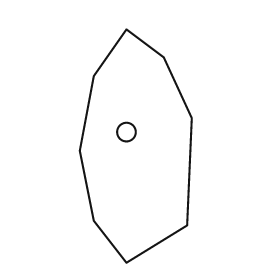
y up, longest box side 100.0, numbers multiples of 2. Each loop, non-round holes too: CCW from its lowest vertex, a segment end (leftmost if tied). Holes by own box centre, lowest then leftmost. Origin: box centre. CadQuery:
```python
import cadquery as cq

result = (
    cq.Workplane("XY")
    .moveTo(-4.0, -50.0)
    .lineTo(22.0, -34.0)
    .lineTo(24.0, 12.0)
    .lineTo(12.0, 38.0)
    .lineTo(-4.0, 50.0)
    .lineTo(-18.0, 30.0)
    .lineTo(-24.0, -2.0)
    .lineTo(-18.0, -32.0)
    .close()
    .moveTo(-4.0, 6.0)
    .circle(4.0)
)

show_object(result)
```